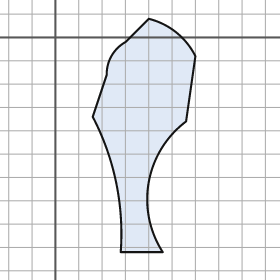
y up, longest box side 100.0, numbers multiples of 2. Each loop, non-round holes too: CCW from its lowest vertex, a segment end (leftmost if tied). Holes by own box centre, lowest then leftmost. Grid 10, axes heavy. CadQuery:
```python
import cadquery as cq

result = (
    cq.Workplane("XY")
    .moveTo(28.0, -92.0)
    .lineTo(46.0, -92.0)
    .threePointArc((40.0, -62.0), (56.0, -36.0))
    .lineTo(60.0, -8.0)
    .threePointArc((52.0, 2.0), (40.0, 8.0))
    .lineTo(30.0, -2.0)
    .threePointArc((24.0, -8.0), (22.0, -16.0))
    .lineTo(16.0, -34.0)
    .threePointArc((26.0, -62.0), (28.0, -92.0))
    .close()
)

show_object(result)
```